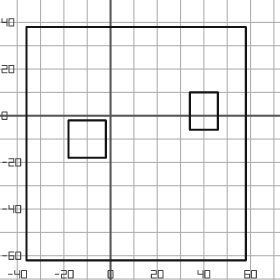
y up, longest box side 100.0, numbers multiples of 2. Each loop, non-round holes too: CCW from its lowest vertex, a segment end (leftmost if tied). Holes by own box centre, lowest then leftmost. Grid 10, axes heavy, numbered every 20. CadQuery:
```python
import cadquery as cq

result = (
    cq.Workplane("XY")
    .moveTo(-36.0, -62.0)
    .lineTo(58.0, -62.0)
    .lineTo(58.0, 38.0)
    .lineTo(-36.0, 38.0)
    .close()
    .moveTo(-18.0, -18.0)
    .lineTo(-2.0, -18.0)
    .lineTo(-2.0, -2.0)
    .lineTo(-18.0, -2.0)
    .close()
    .moveTo(34.0, -6.0)
    .lineTo(46.0, -6.0)
    .lineTo(46.0, 10.0)
    .lineTo(34.0, 10.0)
    .close()
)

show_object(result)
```